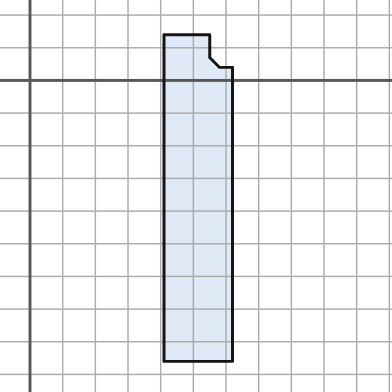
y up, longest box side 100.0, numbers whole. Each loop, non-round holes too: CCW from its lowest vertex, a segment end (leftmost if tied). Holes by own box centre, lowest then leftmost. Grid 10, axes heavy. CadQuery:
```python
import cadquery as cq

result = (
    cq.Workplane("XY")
    .moveTo(41.0, -86.0)
    .lineTo(62.0, -86.0)
    .lineTo(62.0, 4.0)
    .lineTo(58.0, 4.0)
    .lineTo(55.0, 7.0)
    .lineTo(55.0, 14.0)
    .lineTo(41.0, 14.0)
    .close()
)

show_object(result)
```